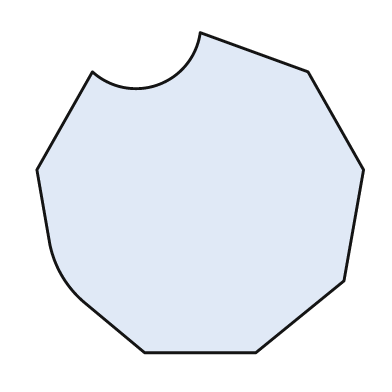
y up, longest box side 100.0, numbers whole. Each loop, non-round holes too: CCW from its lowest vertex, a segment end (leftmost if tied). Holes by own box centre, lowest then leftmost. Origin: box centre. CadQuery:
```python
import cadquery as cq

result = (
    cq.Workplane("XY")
    .moveTo(-17.0, -49.0)
    .lineTo(17.0, -49.0)
    .lineTo(44.0, -27.0)
    .lineTo(50.0, 7.0)
    .lineTo(33.0, 37.0)
    .lineTo(0.0, 49.0)
    .threePointArc((-13.0, 33.0), (-33.0, 37.0))
    .lineTo(-50.0, 7.0)
    .lineTo(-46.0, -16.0)
    .threePointArc((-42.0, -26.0), (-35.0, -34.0))
    .close()
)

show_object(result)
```